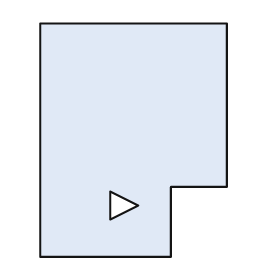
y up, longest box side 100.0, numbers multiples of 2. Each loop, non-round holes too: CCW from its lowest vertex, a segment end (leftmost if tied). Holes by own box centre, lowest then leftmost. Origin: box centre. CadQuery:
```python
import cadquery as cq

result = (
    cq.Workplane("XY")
    .moveTo(-40.0, -50.0)
    .lineTo(16.0, -50.0)
    .lineTo(16.0, -20.0)
    .lineTo(40.0, -20.0)
    .lineTo(40.0, 50.0)
    .lineTo(-40.0, 50.0)
    .close()
    .moveTo(-10.0, -34.0)
    .lineTo(2.0, -28.0)
    .lineTo(-10.0, -22.0)
    .close()
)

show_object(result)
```